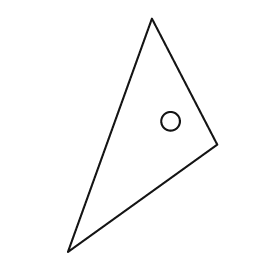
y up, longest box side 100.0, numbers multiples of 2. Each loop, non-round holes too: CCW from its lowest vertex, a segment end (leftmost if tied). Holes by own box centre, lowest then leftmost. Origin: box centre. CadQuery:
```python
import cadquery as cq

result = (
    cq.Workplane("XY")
    .moveTo(-32.0, -50.0)
    .lineTo(32.0, -4.0)
    .lineTo(4.0, 50.0)
    .close()
    .moveTo(12.0, 6.0)
    .circle(4.0)
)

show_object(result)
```